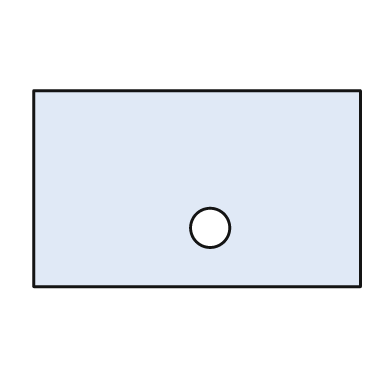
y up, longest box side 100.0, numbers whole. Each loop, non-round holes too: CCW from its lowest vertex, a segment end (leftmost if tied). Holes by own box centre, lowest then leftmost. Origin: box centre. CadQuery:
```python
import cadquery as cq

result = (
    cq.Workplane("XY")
    .moveTo(-50.0, -30.0)
    .lineTo(50.0, -30.0)
    .lineTo(50.0, 30.0)
    .lineTo(-50.0, 30.0)
    .close()
    .moveTo(4.0, -12.0)
    .circle(6.0)
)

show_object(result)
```